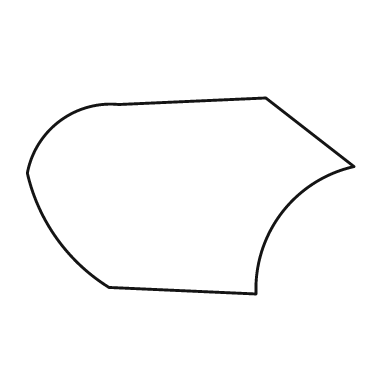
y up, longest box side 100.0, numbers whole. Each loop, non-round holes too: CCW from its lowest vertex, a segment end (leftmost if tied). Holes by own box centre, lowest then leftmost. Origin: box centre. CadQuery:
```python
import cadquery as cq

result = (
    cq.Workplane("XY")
    .moveTo(20.0, -30.0)
    .threePointArc((28.0, -5.0), (50.0, 9.0))
    .lineTo(23.0, 30.0)
    .lineTo(-22.0, 28.0)
    .threePointArc((-40.0, 23.0), (-50.0, 7.0))
    .threePointArc((-41.0, -13.0), (-25.0, -28.0))
    .close()
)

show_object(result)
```